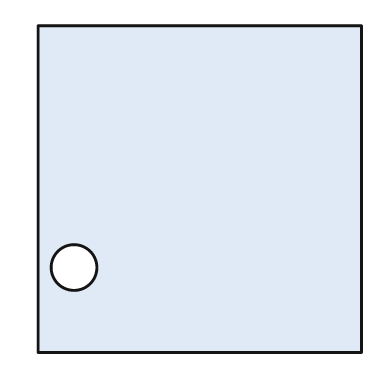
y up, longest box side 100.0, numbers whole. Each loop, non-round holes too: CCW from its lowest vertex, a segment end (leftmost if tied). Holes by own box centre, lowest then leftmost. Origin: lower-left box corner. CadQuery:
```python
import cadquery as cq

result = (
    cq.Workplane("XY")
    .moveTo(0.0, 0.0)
    .lineTo(99.0, 0.0)
    .lineTo(99.0, 100.0)
    .lineTo(0.0, 100.0)
    .close()
    .moveTo(11.0, 26.0)
    .circle(7.0)
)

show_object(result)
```